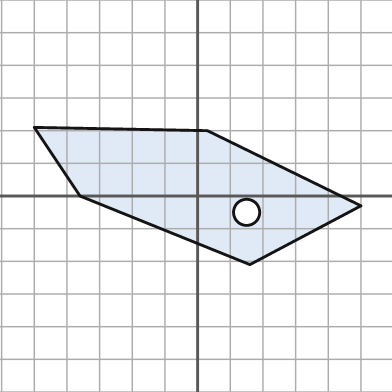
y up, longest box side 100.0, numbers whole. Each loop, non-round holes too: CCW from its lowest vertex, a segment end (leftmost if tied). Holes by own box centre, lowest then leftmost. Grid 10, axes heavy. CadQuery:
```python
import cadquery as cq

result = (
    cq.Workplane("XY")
    .moveTo(16.0, -21.0)
    .lineTo(50.0, -3.0)
    .lineTo(3.0, 20.0)
    .lineTo(-50.0, 21.0)
    .lineTo(-36.0, 0.0)
    .close()
    .moveTo(15.0, -5.0)
    .circle(4.0)
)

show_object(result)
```